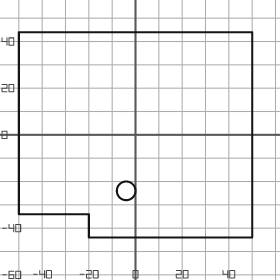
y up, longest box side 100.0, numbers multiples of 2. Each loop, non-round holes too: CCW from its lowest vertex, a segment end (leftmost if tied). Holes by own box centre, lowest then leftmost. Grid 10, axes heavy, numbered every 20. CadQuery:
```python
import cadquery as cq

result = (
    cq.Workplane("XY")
    .moveTo(-20.0, -44.0)
    .lineTo(50.0, -44.0)
    .lineTo(50.0, 44.0)
    .lineTo(-50.0, 44.0)
    .lineTo(-50.0, -34.0)
    .lineTo(-20.0, -34.0)
    .close()
    .moveTo(-4.0, -24.0)
    .circle(4.0)
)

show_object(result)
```